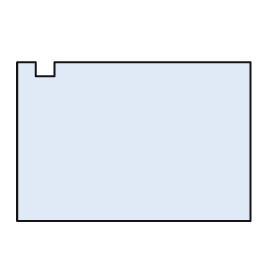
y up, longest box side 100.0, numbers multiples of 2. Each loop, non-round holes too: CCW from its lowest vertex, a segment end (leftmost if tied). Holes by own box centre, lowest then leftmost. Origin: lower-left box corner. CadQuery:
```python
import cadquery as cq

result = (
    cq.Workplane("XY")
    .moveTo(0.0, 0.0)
    .lineTo(100.0, 0.0)
    .lineTo(100.0, 68.0)
    .lineTo(16.0, 68.0)
    .lineTo(16.0, 62.0)
    .lineTo(8.0, 62.0)
    .lineTo(8.0, 68.0)
    .lineTo(0.0, 68.0)
    .close()
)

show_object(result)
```